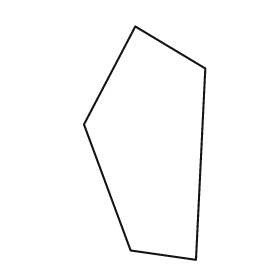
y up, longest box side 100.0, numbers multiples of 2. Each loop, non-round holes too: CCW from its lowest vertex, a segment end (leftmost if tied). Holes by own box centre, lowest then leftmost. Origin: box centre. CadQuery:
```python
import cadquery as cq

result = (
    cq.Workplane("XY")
    .moveTo(22.0, -50.0)
    .lineTo(26.0, 32.0)
    .lineTo(-4.0, 50.0)
    .lineTo(-26.0, 8.0)
    .lineTo(-6.0, -46.0)
    .close()
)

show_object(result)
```